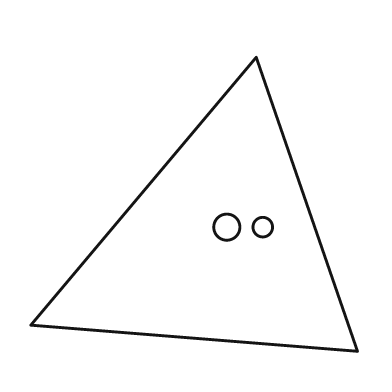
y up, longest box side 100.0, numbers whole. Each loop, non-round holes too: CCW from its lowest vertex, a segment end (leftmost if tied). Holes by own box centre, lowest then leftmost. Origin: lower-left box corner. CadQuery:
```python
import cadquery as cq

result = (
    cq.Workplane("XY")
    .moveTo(100.0, 0.0)
    .lineTo(69.0, 90.0)
    .lineTo(0.0, 8.0)
    .close()
    .moveTo(60.0, 38.0)
    .circle(4.0)
    .moveTo(71.0, 38.0)
    .circle(3.0)
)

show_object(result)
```